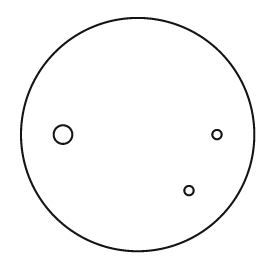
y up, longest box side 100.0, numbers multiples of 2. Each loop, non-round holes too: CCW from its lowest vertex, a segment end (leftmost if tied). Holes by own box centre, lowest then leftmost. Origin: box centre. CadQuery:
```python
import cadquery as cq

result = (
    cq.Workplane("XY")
    .moveTo(0.0, 0.0)
    .circle(50.0)
    .moveTo(22.0, -24.0)
    .circle(2.0)
    .moveTo(-32.0, 0.0)
    .circle(4.0)
    .moveTo(34.0, 0.0)
    .circle(2.0)
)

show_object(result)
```